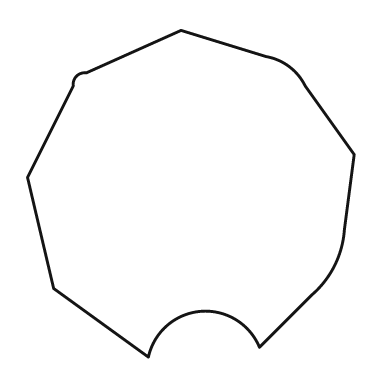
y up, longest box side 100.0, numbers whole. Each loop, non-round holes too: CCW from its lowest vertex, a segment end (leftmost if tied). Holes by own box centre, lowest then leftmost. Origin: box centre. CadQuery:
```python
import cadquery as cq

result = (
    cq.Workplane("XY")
    .moveTo(-13.0, -50.0)
    .threePointArc((3.0, -36.0), (21.0, -47.0))
    .lineTo(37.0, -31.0)
    .threePointArc((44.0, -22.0), (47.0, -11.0))
    .lineTo(50.0, 12.0)
    .lineTo(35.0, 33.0)
    .threePointArc((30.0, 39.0), (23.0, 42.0))
    .lineTo(-3.0, 50.0)
    .lineTo(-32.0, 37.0)
    .threePointArc((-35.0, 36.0), (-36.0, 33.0))
    .lineTo(-50.0, 5.0)
    .lineTo(-42.0, -29.0)
    .close()
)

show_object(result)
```